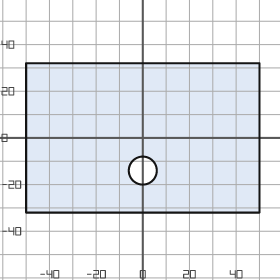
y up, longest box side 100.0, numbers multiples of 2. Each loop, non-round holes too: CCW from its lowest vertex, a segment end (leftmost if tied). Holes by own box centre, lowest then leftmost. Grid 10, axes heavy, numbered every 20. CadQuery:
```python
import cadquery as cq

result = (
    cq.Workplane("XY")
    .moveTo(-50.0, -32.0)
    .lineTo(50.0, -32.0)
    .lineTo(50.0, 32.0)
    .lineTo(-50.0, 32.0)
    .close()
    .moveTo(0.0, -14.0)
    .circle(6.0)
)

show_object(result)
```